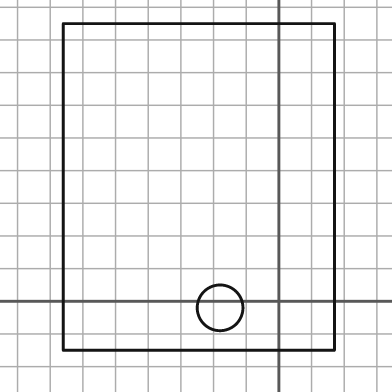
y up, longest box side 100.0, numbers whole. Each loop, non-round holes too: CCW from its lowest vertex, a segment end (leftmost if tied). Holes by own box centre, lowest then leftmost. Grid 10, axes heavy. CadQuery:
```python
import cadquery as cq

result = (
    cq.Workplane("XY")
    .moveTo(-66.0, -15.0)
    .lineTo(17.0, -15.0)
    .lineTo(17.0, 85.0)
    .lineTo(-66.0, 85.0)
    .close()
    .moveTo(-18.0, -2.0)
    .circle(7.0)
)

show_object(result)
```